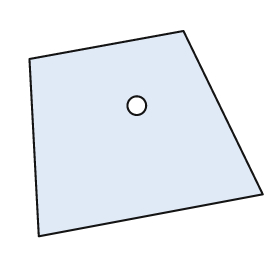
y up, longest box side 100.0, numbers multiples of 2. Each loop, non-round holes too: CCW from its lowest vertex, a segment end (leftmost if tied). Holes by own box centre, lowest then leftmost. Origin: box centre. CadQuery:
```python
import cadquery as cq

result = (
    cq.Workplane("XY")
    .moveTo(-46.0, -44.0)
    .lineTo(50.0, -26.0)
    .lineTo(16.0, 44.0)
    .lineTo(-50.0, 32.0)
    .close()
    .moveTo(-4.0, 12.0)
    .circle(4.0)
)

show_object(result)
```